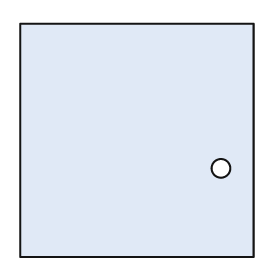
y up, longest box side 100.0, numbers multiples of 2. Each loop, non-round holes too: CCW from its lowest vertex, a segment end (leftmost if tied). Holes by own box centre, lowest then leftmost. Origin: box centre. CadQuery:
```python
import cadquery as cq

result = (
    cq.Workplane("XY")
    .moveTo(-50.0, -50.0)
    .lineTo(50.0, -50.0)
    .lineTo(50.0, 50.0)
    .lineTo(-50.0, 50.0)
    .close()
    .moveTo(36.0, -12.0)
    .circle(4.0)
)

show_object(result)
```